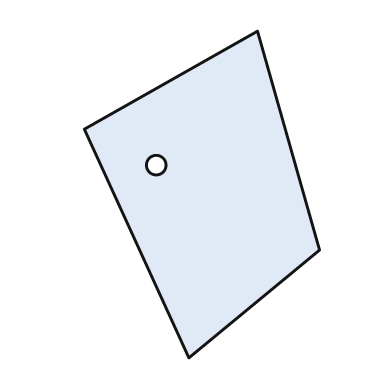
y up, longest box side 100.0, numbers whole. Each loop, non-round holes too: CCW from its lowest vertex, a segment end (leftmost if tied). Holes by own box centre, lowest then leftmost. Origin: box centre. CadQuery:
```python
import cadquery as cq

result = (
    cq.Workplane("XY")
    .moveTo(-4.0, -50.0)
    .lineTo(36.0, -17.0)
    .lineTo(17.0, 50.0)
    .lineTo(-36.0, 20.0)
    .close()
    .moveTo(-14.0, 9.0)
    .circle(3.0)
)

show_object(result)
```